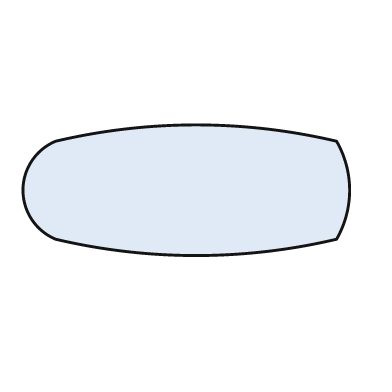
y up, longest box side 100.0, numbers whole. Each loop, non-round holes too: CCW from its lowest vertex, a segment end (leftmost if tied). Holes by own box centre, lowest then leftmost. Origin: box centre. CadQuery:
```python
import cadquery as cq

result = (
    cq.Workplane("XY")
    .moveTo(-40.0, -15.0)
    .threePointArc((3.0, -20.0), (46.0, -15.0))
    .threePointArc((50.0, 0.0), (46.0, 15.0))
    .threePointArc((3.0, 20.0), (-40.0, 15.0))
    .threePointArc((-50.0, 0.0), (-40.0, -15.0))
    .close()
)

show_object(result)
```